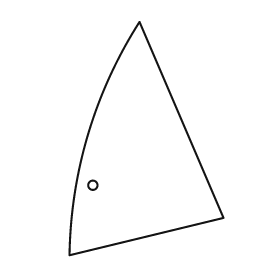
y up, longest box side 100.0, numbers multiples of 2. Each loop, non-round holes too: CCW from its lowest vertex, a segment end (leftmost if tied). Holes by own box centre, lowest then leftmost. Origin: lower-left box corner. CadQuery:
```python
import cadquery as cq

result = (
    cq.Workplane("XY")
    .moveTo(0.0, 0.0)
    .lineTo(66.0, 16.0)
    .lineTo(30.0, 100.0)
    .threePointArc((8.0, 52.0), (0.0, 0.0))
    .close()
    .moveTo(10.0, 30.0)
    .circle(2.0)
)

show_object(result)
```